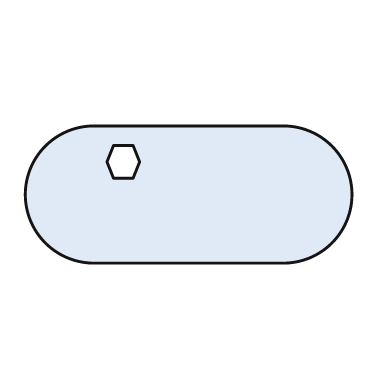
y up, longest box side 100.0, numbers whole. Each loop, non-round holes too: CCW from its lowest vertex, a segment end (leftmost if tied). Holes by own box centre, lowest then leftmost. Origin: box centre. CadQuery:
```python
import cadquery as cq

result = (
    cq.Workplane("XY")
    .moveTo(-29.0, -21.0)
    .lineTo(29.0, -21.0)
    .threePointArc((50.0, 0.0), (29.0, 21.0))
    .lineTo(-29.0, 21.0)
    .threePointArc((-50.0, 0.0), (-29.0, -21.0))
    .close()
    .moveTo(-23.0, 5.0)
    .lineTo(-17.0, 5.0)
    .lineTo(-15.0, 10.0)
    .lineTo(-17.0, 15.0)
    .lineTo(-23.0, 15.0)
    .lineTo(-25.0, 10.0)
    .close()
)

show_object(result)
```